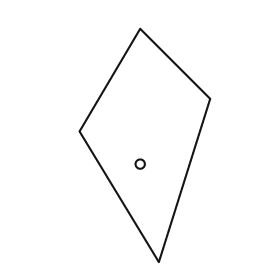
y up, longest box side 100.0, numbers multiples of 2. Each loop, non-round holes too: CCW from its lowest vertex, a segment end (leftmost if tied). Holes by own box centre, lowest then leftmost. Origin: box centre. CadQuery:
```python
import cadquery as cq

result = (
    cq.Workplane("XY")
    .moveTo(6.0, -50.0)
    .lineTo(28.0, 20.0)
    .lineTo(-2.0, 50.0)
    .lineTo(-28.0, 6.0)
    .close()
    .moveTo(-2.0, -8.0)
    .circle(2.0)
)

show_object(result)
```